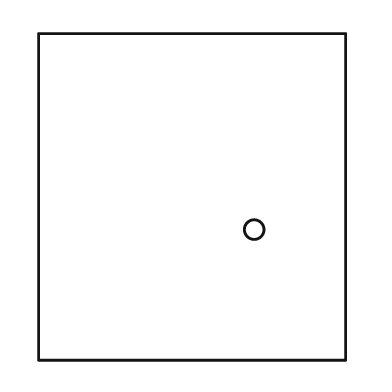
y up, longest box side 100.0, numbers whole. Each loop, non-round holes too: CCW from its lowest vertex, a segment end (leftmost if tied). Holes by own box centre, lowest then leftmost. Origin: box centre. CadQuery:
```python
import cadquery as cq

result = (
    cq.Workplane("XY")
    .moveTo(-47.0, -50.0)
    .lineTo(47.0, -50.0)
    .lineTo(47.0, 50.0)
    .lineTo(-47.0, 50.0)
    .close()
    .moveTo(19.0, -10.0)
    .circle(3.0)
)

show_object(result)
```